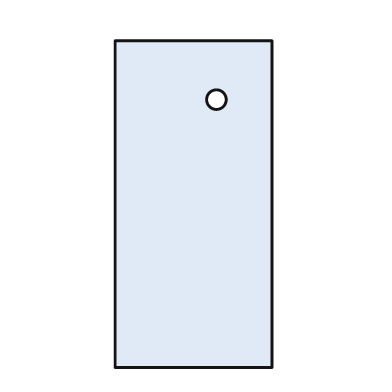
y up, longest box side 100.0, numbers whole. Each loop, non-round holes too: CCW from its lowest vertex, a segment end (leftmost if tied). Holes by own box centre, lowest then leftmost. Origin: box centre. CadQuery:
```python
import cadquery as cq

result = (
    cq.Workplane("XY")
    .moveTo(-24.0, -50.0)
    .lineTo(24.0, -50.0)
    .lineTo(24.0, 50.0)
    .lineTo(-24.0, 50.0)
    .close()
    .moveTo(7.0, 32.0)
    .circle(3.0)
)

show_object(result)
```